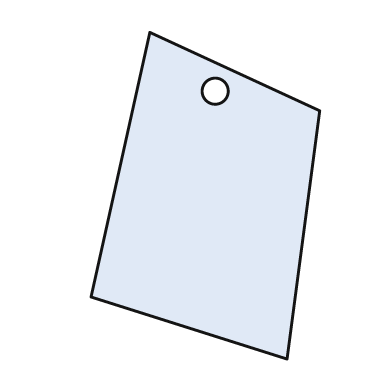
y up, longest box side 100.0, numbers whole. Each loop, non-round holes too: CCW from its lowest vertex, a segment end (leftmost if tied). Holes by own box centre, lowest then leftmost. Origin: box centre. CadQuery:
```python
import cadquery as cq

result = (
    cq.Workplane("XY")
    .moveTo(25.0, -50.0)
    .lineTo(35.0, 26.0)
    .lineTo(-17.0, 50.0)
    .lineTo(-35.0, -31.0)
    .close()
    .moveTo(3.0, 32.0)
    .circle(4.0)
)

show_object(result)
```